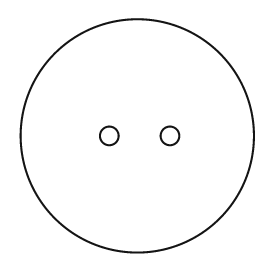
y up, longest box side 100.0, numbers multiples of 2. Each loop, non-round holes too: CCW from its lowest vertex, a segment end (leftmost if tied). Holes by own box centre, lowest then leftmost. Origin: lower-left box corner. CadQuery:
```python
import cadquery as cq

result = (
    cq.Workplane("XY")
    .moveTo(50.0, 50.0)
    .circle(50.0)
    .moveTo(38.0, 50.0)
    .circle(4.0)
    .moveTo(64.0, 50.0)
    .circle(4.0)
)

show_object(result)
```